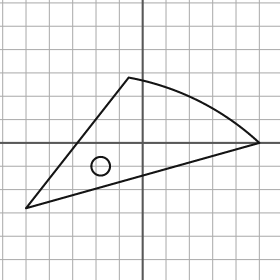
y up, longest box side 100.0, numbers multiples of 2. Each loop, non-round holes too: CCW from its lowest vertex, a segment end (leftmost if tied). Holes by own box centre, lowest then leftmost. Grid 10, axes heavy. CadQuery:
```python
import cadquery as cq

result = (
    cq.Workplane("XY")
    .moveTo(-50.0, -28.0)
    .lineTo(50.0, 0.0)
    .threePointArc((24.0, 18.0), (-6.0, 28.0))
    .close()
    .moveTo(-18.0, -10.0)
    .circle(4.0)
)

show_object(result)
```